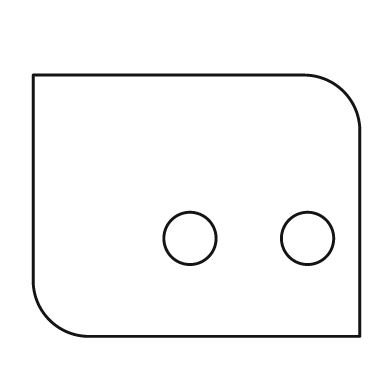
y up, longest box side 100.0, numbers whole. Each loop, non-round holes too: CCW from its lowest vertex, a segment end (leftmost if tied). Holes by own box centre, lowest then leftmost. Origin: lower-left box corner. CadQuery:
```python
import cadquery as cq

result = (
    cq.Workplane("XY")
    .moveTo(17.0, 0.0)
    .lineTo(100.0, 0.0)
    .lineTo(100.0, 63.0)
    .threePointArc((95.0, 75.0), (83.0, 80.0))
    .lineTo(0.0, 80.0)
    .lineTo(0.0, 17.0)
    .threePointArc((5.0, 5.0), (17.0, 0.0))
    .close()
    .moveTo(48.0, 30.0)
    .circle(8.0)
    .moveTo(84.0, 30.0)
    .circle(8.0)
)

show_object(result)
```